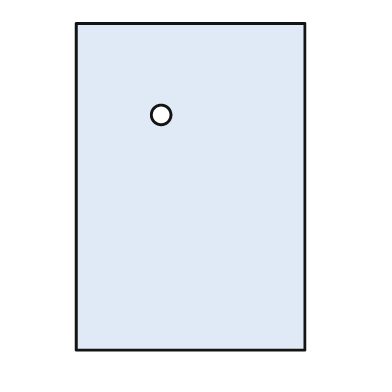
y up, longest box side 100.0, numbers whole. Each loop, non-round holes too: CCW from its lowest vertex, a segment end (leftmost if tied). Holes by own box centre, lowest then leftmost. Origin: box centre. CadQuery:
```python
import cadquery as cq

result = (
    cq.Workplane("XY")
    .moveTo(-35.0, -50.0)
    .lineTo(35.0, -50.0)
    .lineTo(35.0, 50.0)
    .lineTo(-35.0, 50.0)
    .close()
    .moveTo(-9.0, 22.0)
    .circle(3.0)
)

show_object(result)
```